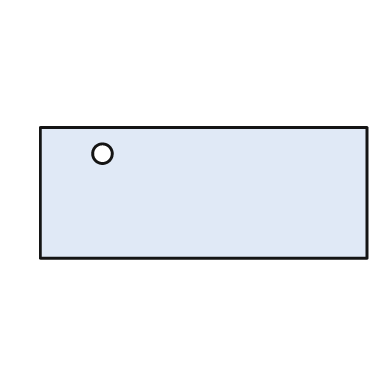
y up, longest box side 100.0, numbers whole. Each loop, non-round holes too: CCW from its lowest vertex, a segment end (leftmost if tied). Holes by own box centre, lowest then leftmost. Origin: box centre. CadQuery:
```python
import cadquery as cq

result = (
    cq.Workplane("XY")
    .moveTo(-50.0, -20.0)
    .lineTo(50.0, -20.0)
    .lineTo(50.0, 20.0)
    .lineTo(-50.0, 20.0)
    .close()
    .moveTo(-31.0, 12.0)
    .circle(3.0)
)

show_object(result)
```